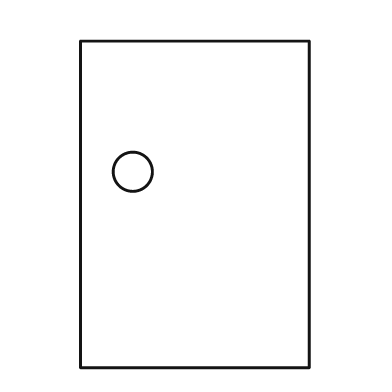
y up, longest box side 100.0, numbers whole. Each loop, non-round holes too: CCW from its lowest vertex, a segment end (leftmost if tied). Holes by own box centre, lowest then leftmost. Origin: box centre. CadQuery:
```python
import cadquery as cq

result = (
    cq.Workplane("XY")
    .moveTo(-35.0, -50.0)
    .lineTo(35.0, -50.0)
    .lineTo(35.0, 50.0)
    .lineTo(-35.0, 50.0)
    .close()
    .moveTo(-19.0, 10.0)
    .circle(6.0)
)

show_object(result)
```